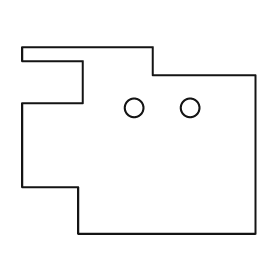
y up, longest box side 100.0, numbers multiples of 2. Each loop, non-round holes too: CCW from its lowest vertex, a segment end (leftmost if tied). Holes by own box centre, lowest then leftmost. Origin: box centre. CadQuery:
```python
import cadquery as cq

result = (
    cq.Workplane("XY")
    .moveTo(-26.0, -40.0)
    .lineTo(50.0, -40.0)
    .lineTo(50.0, 28.0)
    .lineTo(6.0, 28.0)
    .lineTo(6.0, 40.0)
    .lineTo(-50.0, 40.0)
    .lineTo(-50.0, 34.0)
    .lineTo(-24.0, 34.0)
    .lineTo(-24.0, 16.0)
    .lineTo(-50.0, 16.0)
    .lineTo(-50.0, -20.0)
    .lineTo(-26.0, -20.0)
    .close()
    .moveTo(-2.0, 14.0)
    .circle(4.0)
    .moveTo(22.0, 14.0)
    .circle(4.0)
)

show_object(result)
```